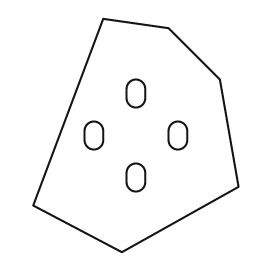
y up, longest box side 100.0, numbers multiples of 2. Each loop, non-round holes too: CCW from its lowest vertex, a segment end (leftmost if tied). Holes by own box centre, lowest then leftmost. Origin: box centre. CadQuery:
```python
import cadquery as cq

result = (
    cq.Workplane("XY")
    .moveTo(-6.0, -50.0)
    .lineTo(44.0, -22.0)
    .lineTo(36.0, 24.0)
    .lineTo(14.0, 46.0)
    .lineTo(-14.0, 50.0)
    .lineTo(-44.0, -30.0)
    .close()
    .moveTo(-4.0, -20.0)
    .threePointArc((0.0, -24.0), (4.0, -20.0))
    .lineTo(4.0, -16.0)
    .threePointArc((0.0, -12.0), (-4.0, -16.0))
    .close()
    .moveTo(-22.0, -2.0)
    .threePointArc((-18.0, -6.0), (-14.0, -2.0))
    .lineTo(-14.0, 2.0)
    .threePointArc((-18.0, 6.0), (-22.0, 2.0))
    .close()
    .moveTo(14.0, -2.0)
    .threePointArc((18.0, -6.0), (22.0, -2.0))
    .lineTo(22.0, 2.0)
    .threePointArc((18.0, 6.0), (14.0, 2.0))
    .close()
    .moveTo(-4.0, 16.0)
    .threePointArc((0.0, 12.0), (4.0, 16.0))
    .lineTo(4.0, 20.0)
    .threePointArc((0.0, 24.0), (-4.0, 20.0))
    .close()
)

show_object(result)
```